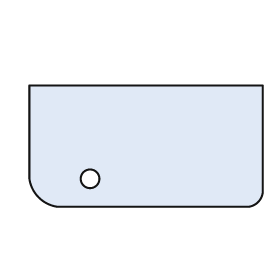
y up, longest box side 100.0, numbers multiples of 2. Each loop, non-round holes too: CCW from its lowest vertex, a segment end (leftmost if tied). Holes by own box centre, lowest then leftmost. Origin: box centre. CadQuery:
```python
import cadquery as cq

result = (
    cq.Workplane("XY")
    .moveTo(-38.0, -26.0)
    .lineTo(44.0, -26.0)
    .threePointArc((48.0, -24.0), (50.0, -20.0))
    .lineTo(50.0, 26.0)
    .lineTo(-50.0, 26.0)
    .lineTo(-50.0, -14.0)
    .threePointArc((-46.0, -22.0), (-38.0, -26.0))
    .close()
    .moveTo(-24.0, -14.0)
    .circle(4.0)
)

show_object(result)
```